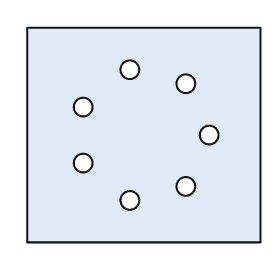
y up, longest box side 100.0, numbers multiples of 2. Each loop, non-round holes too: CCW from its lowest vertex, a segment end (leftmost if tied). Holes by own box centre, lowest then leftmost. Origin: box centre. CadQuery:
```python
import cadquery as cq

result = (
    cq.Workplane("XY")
    .moveTo(-50.0, -46.0)
    .lineTo(50.0, -46.0)
    .lineTo(50.0, 46.0)
    .lineTo(-50.0, 46.0)
    .close()
    .moveTo(-6.0, -28.0)
    .circle(4.0)
    .moveTo(18.0, -22.0)
    .circle(4.0)
    .moveTo(-26.0, -12.0)
    .circle(4.0)
    .moveTo(28.0, 0.0)
    .circle(4.0)
    .moveTo(-26.0, 12.0)
    .circle(4.0)
    .moveTo(18.0, 22.0)
    .circle(4.0)
    .moveTo(-6.0, 28.0)
    .circle(4.0)
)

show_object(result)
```